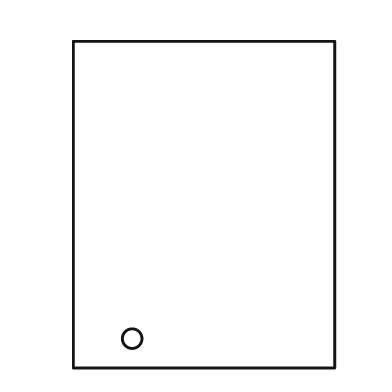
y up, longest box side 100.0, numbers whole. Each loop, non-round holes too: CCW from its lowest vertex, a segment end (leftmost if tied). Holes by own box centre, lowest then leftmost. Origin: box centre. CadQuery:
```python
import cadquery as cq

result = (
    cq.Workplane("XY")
    .moveTo(-40.0, -50.0)
    .lineTo(40.0, -50.0)
    .lineTo(40.0, 50.0)
    .lineTo(-40.0, 50.0)
    .close()
    .moveTo(-22.0, -41.0)
    .circle(3.0)
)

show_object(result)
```